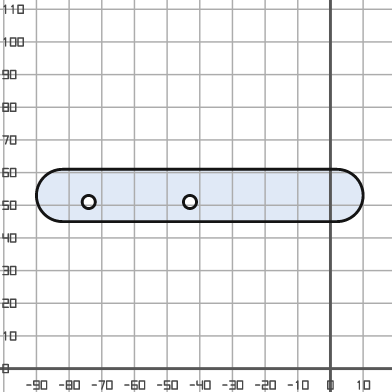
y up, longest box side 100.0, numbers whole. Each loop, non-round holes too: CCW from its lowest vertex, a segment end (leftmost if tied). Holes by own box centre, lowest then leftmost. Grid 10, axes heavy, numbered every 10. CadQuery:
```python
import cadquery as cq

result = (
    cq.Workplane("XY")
    .moveTo(-82.0, 45.0)
    .lineTo(2.0, 45.0)
    .threePointArc((10.0, 53.0), (2.0, 61.0))
    .lineTo(-82.0, 61.0)
    .threePointArc((-90.0, 53.0), (-82.0, 45.0))
    .close()
    .moveTo(-74.0, 51.0)
    .circle(2.0)
    .moveTo(-43.0, 51.0)
    .circle(2.0)
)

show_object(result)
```